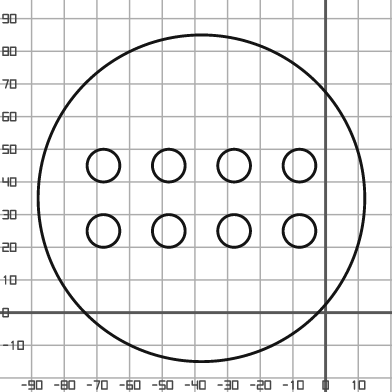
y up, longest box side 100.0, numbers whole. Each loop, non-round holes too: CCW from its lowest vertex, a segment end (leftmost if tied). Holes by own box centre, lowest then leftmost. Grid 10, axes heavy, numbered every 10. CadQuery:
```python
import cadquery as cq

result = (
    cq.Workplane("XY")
    .moveTo(-38.0, 35.0)
    .circle(50.0)
    .moveTo(-68.0, 25.0)
    .circle(5.0)
    .moveTo(-48.0, 25.0)
    .circle(5.0)
    .moveTo(-28.0, 25.0)
    .circle(5.0)
    .moveTo(-8.0, 25.0)
    .circle(5.0)
    .moveTo(-68.0, 45.0)
    .circle(5.0)
    .moveTo(-48.0, 45.0)
    .circle(5.0)
    .moveTo(-28.0, 45.0)
    .circle(5.0)
    .moveTo(-8.0, 45.0)
    .circle(5.0)
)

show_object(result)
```